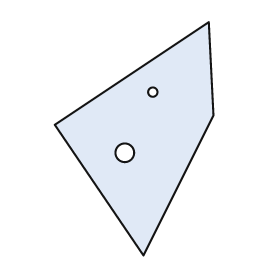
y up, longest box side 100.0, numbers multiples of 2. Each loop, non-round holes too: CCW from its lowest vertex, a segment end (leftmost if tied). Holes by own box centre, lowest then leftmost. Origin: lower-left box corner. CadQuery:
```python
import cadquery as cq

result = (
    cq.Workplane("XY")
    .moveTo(38.0, 0.0)
    .lineTo(68.0, 60.0)
    .lineTo(66.0, 100.0)
    .lineTo(0.0, 56.0)
    .close()
    .moveTo(30.0, 44.0)
    .circle(4.0)
    .moveTo(42.0, 70.0)
    .circle(2.0)
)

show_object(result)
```